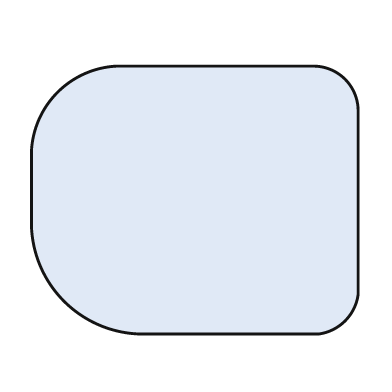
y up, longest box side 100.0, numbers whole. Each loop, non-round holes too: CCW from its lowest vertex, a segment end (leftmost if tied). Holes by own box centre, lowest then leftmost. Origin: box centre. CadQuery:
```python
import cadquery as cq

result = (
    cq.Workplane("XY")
    .moveTo(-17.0, -41.0)
    .lineTo(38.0, -41.0)
    .threePointArc((46.0, -37.0), (50.0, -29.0))
    .lineTo(50.0, 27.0)
    .threePointArc((46.0, 37.0), (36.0, 41.0))
    .lineTo(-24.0, 41.0)
    .threePointArc((-42.0, 33.0), (-50.0, 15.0))
    .lineTo(-50.0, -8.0)
    .threePointArc((-40.0, -31.0), (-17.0, -41.0))
    .close()
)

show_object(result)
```